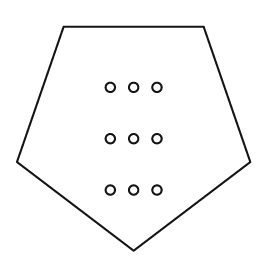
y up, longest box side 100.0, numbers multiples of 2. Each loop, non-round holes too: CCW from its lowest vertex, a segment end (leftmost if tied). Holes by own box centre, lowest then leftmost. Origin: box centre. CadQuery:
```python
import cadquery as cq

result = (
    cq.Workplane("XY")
    .moveTo(0.0, -48.0)
    .lineTo(50.0, -10.0)
    .lineTo(30.0, 48.0)
    .lineTo(-30.0, 48.0)
    .lineTo(-50.0, -10.0)
    .close()
    .moveTo(-10.0, -22.0)
    .circle(2.0)
    .moveTo(0.0, -22.0)
    .circle(2.0)
    .moveTo(10.0, -22.0)
    .circle(2.0)
    .moveTo(-10.0, 0.0)
    .circle(2.0)
    .moveTo(0.0, 0.0)
    .circle(2.0)
    .moveTo(10.0, 0.0)
    .circle(2.0)
    .moveTo(-10.0, 22.0)
    .circle(2.0)
    .moveTo(0.0, 22.0)
    .circle(2.0)
    .moveTo(10.0, 22.0)
    .circle(2.0)
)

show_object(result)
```